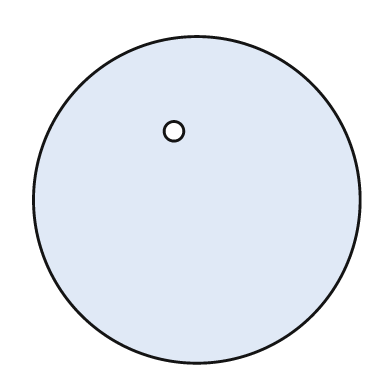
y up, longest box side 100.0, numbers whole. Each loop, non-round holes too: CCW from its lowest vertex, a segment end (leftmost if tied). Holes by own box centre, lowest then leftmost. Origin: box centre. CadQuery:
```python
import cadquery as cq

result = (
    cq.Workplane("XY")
    .moveTo(0.0, 0.0)
    .circle(50.0)
    .moveTo(-7.0, 21.0)
    .circle(3.0)
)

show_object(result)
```